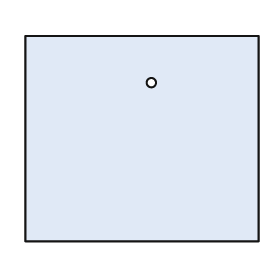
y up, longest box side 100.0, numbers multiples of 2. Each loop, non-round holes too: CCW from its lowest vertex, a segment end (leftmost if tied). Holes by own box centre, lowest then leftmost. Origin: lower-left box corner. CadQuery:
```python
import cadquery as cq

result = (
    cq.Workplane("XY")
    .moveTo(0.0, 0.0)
    .lineTo(100.0, 0.0)
    .lineTo(100.0, 88.0)
    .lineTo(0.0, 88.0)
    .close()
    .moveTo(54.0, 68.0)
    .circle(2.0)
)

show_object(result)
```